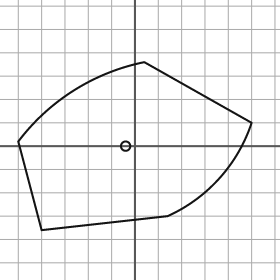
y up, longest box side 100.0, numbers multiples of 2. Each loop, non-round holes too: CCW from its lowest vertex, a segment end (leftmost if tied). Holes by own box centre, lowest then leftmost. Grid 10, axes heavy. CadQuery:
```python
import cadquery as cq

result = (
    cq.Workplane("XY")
    .moveTo(-40.0, -36.0)
    .lineTo(14.0, -30.0)
    .threePointArc((36.0, -14.0), (50.0, 10.0))
    .lineTo(4.0, 36.0)
    .threePointArc((-26.0, 24.0), (-50.0, 2.0))
    .close()
    .moveTo(-4.0, 0.0)
    .circle(2.0)
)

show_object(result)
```